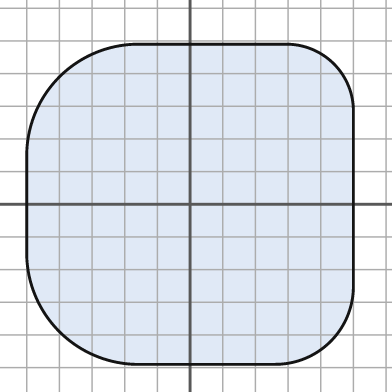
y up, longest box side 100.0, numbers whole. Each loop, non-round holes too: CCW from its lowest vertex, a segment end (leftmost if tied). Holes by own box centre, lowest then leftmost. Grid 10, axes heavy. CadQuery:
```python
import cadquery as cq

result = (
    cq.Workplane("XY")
    .moveTo(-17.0, -49.0)
    .lineTo(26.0, -49.0)
    .threePointArc((43.0, -42.0), (50.0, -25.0))
    .lineTo(50.0, 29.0)
    .threePointArc((44.0, 43.0), (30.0, 49.0))
    .lineTo(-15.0, 49.0)
    .threePointArc((-40.0, 39.0), (-50.0, 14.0))
    .lineTo(-50.0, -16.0)
    .threePointArc((-40.0, -39.0), (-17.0, -49.0))
    .close()
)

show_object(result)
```